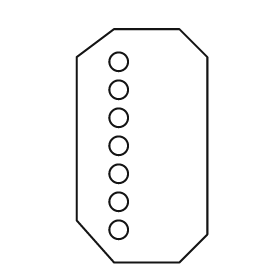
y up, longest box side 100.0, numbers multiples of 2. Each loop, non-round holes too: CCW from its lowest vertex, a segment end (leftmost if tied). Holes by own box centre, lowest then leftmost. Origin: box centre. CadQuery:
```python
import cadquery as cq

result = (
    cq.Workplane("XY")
    .moveTo(-12.0, -50.0)
    .lineTo(16.0, -50.0)
    .lineTo(28.0, -38.0)
    .lineTo(28.0, 38.0)
    .lineTo(16.0, 50.0)
    .lineTo(-12.0, 50.0)
    .lineTo(-28.0, 38.0)
    .lineTo(-28.0, -32.0)
    .close()
    .moveTo(-10.0, -36.0)
    .circle(4.0)
    .moveTo(-10.0, -24.0)
    .circle(4.0)
    .moveTo(-10.0, -12.0)
    .circle(4.0)
    .moveTo(-10.0, 0.0)
    .circle(4.0)
    .moveTo(-10.0, 12.0)
    .circle(4.0)
    .moveTo(-10.0, 24.0)
    .circle(4.0)
    .moveTo(-10.0, 36.0)
    .circle(4.0)
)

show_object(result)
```